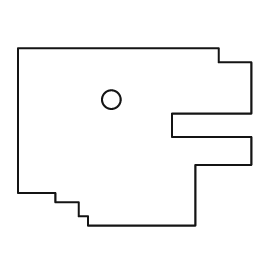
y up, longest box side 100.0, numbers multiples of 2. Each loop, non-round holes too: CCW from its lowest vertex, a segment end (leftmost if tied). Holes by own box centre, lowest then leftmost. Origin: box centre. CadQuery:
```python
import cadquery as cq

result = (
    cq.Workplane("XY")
    .moveTo(-20.0, -38.0)
    .lineTo(26.0, -38.0)
    .lineTo(26.0, -12.0)
    .lineTo(50.0, -12.0)
    .lineTo(50.0, 0.0)
    .lineTo(16.0, 0.0)
    .lineTo(16.0, 10.0)
    .lineTo(50.0, 10.0)
    .lineTo(50.0, 32.0)
    .lineTo(36.0, 32.0)
    .lineTo(36.0, 38.0)
    .lineTo(-50.0, 38.0)
    .lineTo(-50.0, -24.0)
    .lineTo(-34.0, -24.0)
    .lineTo(-34.0, -28.0)
    .lineTo(-24.0, -28.0)
    .lineTo(-24.0, -34.0)
    .lineTo(-20.0, -34.0)
    .close()
    .moveTo(-10.0, 16.0)
    .circle(4.0)
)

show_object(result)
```